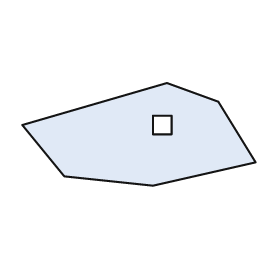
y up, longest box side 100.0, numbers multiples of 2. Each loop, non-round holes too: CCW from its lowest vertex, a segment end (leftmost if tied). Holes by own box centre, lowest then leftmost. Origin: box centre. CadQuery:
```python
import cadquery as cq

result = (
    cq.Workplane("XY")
    .moveTo(6.0, -22.0)
    .lineTo(50.0, -12.0)
    .lineTo(34.0, 14.0)
    .lineTo(12.0, 22.0)
    .lineTo(-50.0, 4.0)
    .lineTo(-32.0, -18.0)
    .close()
    .moveTo(6.0, 0.0)
    .lineTo(14.0, 0.0)
    .lineTo(14.0, 8.0)
    .lineTo(6.0, 8.0)
    .close()
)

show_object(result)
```